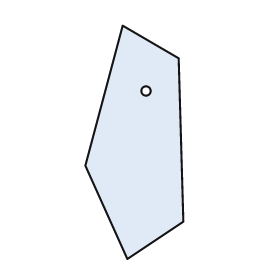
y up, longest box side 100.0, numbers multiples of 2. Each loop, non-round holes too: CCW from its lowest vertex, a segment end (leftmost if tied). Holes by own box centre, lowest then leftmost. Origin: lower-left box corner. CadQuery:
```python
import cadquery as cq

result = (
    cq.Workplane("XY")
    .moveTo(18.0, 0.0)
    .lineTo(42.0, 16.0)
    .lineTo(40.0, 86.0)
    .lineTo(16.0, 100.0)
    .lineTo(0.0, 40.0)
    .close()
    .moveTo(26.0, 72.0)
    .circle(2.0)
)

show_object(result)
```